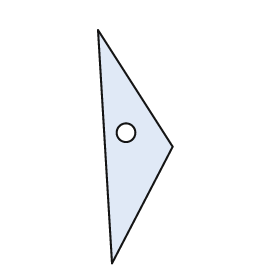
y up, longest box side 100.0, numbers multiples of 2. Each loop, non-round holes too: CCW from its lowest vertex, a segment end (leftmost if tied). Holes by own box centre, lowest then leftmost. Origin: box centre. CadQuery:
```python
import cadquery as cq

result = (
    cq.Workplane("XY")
    .moveTo(-10.0, -50.0)
    .lineTo(16.0, 0.0)
    .lineTo(-16.0, 50.0)
    .close()
    .moveTo(-4.0, 6.0)
    .circle(4.0)
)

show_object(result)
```